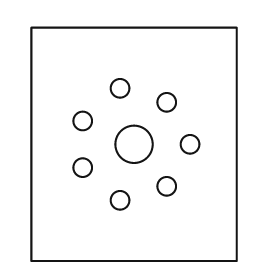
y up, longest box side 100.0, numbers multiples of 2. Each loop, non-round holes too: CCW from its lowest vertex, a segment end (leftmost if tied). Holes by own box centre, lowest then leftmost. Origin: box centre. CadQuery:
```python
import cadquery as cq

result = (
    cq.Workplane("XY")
    .moveTo(-44.0, -50.0)
    .lineTo(44.0, -50.0)
    .lineTo(44.0, 50.0)
    .lineTo(-44.0, 50.0)
    .close()
    .moveTo(-6.0, -24.0)
    .circle(4.0)
    .moveTo(14.0, -18.0)
    .circle(4.0)
    .moveTo(-22.0, -10.0)
    .circle(4.0)
    .moveTo(0.0, 0.0)
    .circle(8.0)
    .moveTo(24.0, 0.0)
    .circle(4.0)
    .moveTo(-22.0, 10.0)
    .circle(4.0)
    .moveTo(14.0, 18.0)
    .circle(4.0)
    .moveTo(-6.0, 24.0)
    .circle(4.0)
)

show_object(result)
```